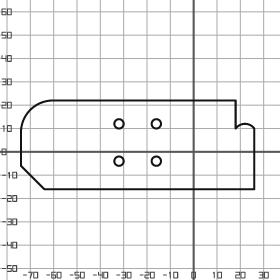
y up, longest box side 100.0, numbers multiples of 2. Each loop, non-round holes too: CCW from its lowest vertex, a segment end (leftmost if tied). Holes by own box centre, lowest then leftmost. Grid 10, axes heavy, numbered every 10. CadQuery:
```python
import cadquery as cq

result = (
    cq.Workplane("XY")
    .moveTo(-64.0, -16.0)
    .lineTo(26.0, -16.0)
    .lineTo(26.0, 10.0)
    .threePointArc((22.0, 12.0), (18.0, 10.0))
    .lineTo(18.0, 22.0)
    .lineTo(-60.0, 22.0)
    .threePointArc((-70.0, 18.0), (-74.0, 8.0))
    .lineTo(-74.0, -6.0)
    .close()
    .moveTo(-32.0, -4.0)
    .circle(2.0)
    .moveTo(-16.0, -4.0)
    .circle(2.0)
    .moveTo(-32.0, 12.0)
    .circle(2.0)
    .moveTo(-16.0, 12.0)
    .circle(2.0)
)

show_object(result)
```